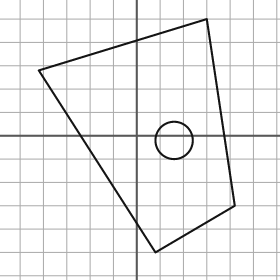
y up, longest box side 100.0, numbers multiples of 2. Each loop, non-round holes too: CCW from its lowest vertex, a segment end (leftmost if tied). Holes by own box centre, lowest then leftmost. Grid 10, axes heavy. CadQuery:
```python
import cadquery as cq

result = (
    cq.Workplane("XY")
    .moveTo(8.0, -50.0)
    .lineTo(42.0, -30.0)
    .lineTo(30.0, 50.0)
    .lineTo(-42.0, 28.0)
    .close()
    .moveTo(16.0, -2.0)
    .circle(8.0)
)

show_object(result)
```